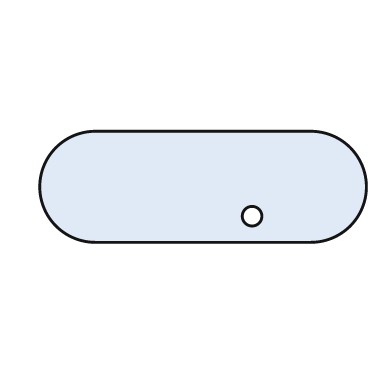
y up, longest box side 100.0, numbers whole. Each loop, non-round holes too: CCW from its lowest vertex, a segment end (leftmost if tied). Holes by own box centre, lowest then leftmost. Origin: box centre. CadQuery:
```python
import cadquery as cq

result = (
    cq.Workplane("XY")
    .moveTo(-33.0, -17.0)
    .lineTo(33.0, -17.0)
    .threePointArc((50.0, 0.0), (33.0, 17.0))
    .lineTo(-33.0, 17.0)
    .threePointArc((-50.0, 0.0), (-33.0, -17.0))
    .close()
    .moveTo(15.0, -9.0)
    .circle(3.0)
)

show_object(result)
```